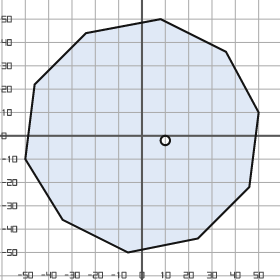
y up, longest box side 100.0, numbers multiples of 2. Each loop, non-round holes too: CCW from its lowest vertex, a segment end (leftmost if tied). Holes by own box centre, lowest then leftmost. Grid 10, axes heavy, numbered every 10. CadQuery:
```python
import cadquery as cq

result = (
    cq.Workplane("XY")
    .moveTo(-6.0, -50.0)
    .lineTo(24.0, -44.0)
    .lineTo(46.0, -22.0)
    .lineTo(50.0, 10.0)
    .lineTo(36.0, 36.0)
    .lineTo(8.0, 50.0)
    .lineTo(-24.0, 44.0)
    .lineTo(-46.0, 22.0)
    .lineTo(-50.0, -10.0)
    .lineTo(-34.0, -36.0)
    .close()
    .moveTo(10.0, -2.0)
    .circle(2.0)
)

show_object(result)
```